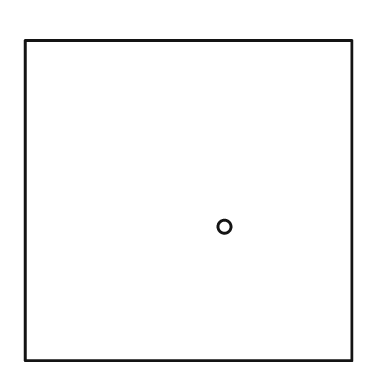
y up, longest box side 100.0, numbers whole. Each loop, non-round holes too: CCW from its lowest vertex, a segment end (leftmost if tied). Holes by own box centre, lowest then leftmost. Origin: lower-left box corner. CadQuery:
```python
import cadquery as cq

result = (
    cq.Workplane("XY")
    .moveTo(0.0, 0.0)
    .lineTo(100.0, 0.0)
    .lineTo(100.0, 98.0)
    .lineTo(0.0, 98.0)
    .close()
    .moveTo(61.0, 41.0)
    .circle(2.0)
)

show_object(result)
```